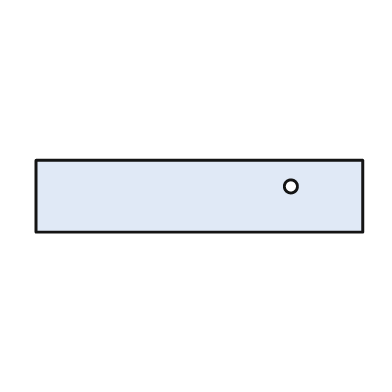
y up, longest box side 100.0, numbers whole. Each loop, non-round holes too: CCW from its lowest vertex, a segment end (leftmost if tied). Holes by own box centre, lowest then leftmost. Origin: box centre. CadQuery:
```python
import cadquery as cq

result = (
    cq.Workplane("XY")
    .moveTo(-50.0, -11.0)
    .lineTo(50.0, -11.0)
    .lineTo(50.0, 11.0)
    .lineTo(-50.0, 11.0)
    .close()
    .moveTo(28.0, 3.0)
    .circle(2.0)
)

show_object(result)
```